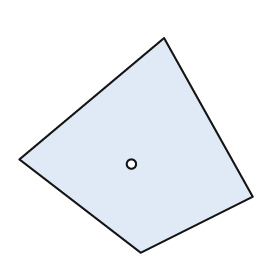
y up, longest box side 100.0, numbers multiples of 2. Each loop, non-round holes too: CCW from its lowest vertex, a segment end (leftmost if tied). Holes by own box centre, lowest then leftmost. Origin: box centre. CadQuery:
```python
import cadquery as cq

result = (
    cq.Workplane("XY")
    .moveTo(2.0, -46.0)
    .lineTo(50.0, -22.0)
    .lineTo(12.0, 46.0)
    .lineTo(-50.0, -6.0)
    .close()
    .moveTo(-2.0, -8.0)
    .circle(2.0)
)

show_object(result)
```